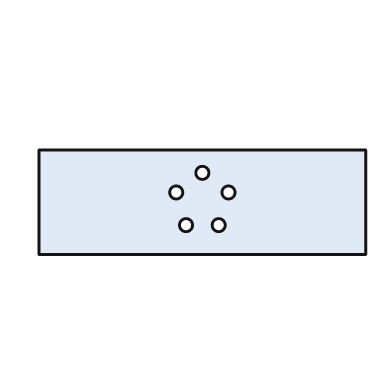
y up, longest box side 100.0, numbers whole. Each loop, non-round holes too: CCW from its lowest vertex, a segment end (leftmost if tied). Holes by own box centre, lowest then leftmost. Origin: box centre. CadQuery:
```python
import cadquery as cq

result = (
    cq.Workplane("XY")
    .moveTo(-50.0, -16.0)
    .lineTo(50.0, -16.0)
    .lineTo(50.0, 16.0)
    .lineTo(-50.0, 16.0)
    .close()
    .moveTo(-5.0, -7.0)
    .circle(2.0)
    .moveTo(5.0, -7.0)
    .circle(2.0)
    .moveTo(-8.0, 3.0)
    .circle(2.0)
    .moveTo(8.0, 3.0)
    .circle(2.0)
    .moveTo(0.0, 9.0)
    .circle(2.0)
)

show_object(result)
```